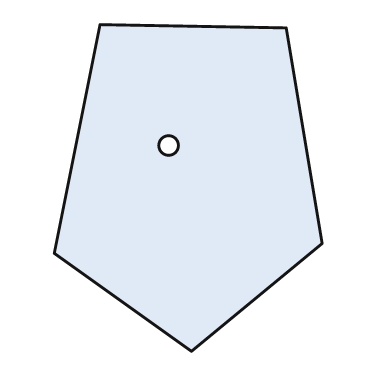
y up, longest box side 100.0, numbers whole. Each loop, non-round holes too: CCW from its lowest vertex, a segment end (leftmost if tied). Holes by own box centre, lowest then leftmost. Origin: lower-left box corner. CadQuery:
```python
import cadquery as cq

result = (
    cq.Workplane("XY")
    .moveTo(42.0, 0.0)
    .lineTo(82.0, 33.0)
    .lineTo(71.0, 99.0)
    .lineTo(14.0, 100.0)
    .lineTo(0.0, 30.0)
    .close()
    .moveTo(35.0, 63.0)
    .circle(3.0)
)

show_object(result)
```